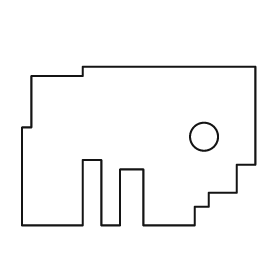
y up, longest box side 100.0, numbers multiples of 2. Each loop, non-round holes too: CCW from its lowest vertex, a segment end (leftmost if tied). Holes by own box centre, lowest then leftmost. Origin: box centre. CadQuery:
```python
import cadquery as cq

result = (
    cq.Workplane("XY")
    .moveTo(-50.0, -34.0)
    .lineTo(-24.0, -34.0)
    .lineTo(-24.0, -6.0)
    .lineTo(-16.0, -6.0)
    .lineTo(-16.0, -34.0)
    .lineTo(-8.0, -34.0)
    .lineTo(-8.0, -10.0)
    .lineTo(2.0, -10.0)
    .lineTo(2.0, -34.0)
    .lineTo(24.0, -34.0)
    .lineTo(24.0, -26.0)
    .lineTo(30.0, -26.0)
    .lineTo(30.0, -20.0)
    .lineTo(42.0, -20.0)
    .lineTo(42.0, -8.0)
    .lineTo(50.0, -8.0)
    .lineTo(50.0, 34.0)
    .lineTo(-24.0, 34.0)
    .lineTo(-24.0, 30.0)
    .lineTo(-46.0, 30.0)
    .lineTo(-46.0, 8.0)
    .lineTo(-50.0, 8.0)
    .close()
    .moveTo(28.0, 4.0)
    .circle(6.0)
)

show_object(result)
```